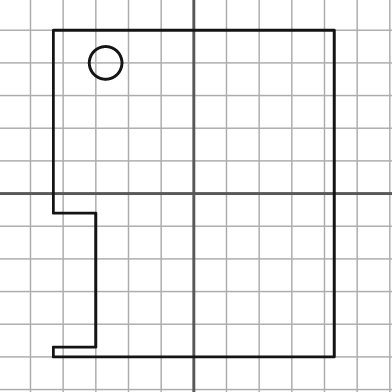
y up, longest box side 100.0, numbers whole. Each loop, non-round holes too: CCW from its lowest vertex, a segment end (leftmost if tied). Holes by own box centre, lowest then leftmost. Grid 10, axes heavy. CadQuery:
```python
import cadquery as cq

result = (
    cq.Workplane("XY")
    .moveTo(-43.0, -50.0)
    .lineTo(43.0, -50.0)
    .lineTo(43.0, 50.0)
    .lineTo(-43.0, 50.0)
    .lineTo(-43.0, -6.0)
    .lineTo(-30.0, -6.0)
    .lineTo(-30.0, -47.0)
    .lineTo(-43.0, -47.0)
    .close()
    .moveTo(-27.0, 40.0)
    .circle(5.0)
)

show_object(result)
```